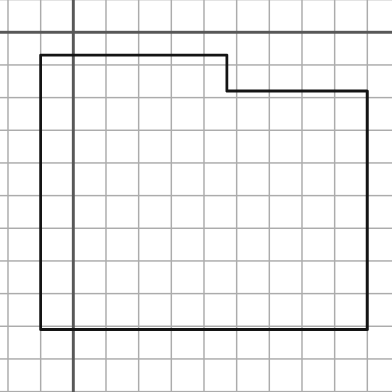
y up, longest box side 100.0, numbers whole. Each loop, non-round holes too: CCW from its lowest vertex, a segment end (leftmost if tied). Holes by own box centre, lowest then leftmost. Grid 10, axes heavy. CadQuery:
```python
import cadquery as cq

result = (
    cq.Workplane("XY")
    .moveTo(-10.0, -91.0)
    .lineTo(90.0, -91.0)
    .lineTo(90.0, -18.0)
    .lineTo(47.0, -18.0)
    .lineTo(47.0, -7.0)
    .lineTo(-10.0, -7.0)
    .close()
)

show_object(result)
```